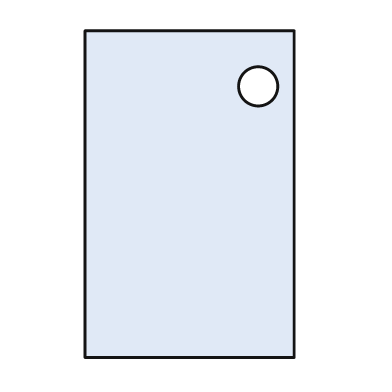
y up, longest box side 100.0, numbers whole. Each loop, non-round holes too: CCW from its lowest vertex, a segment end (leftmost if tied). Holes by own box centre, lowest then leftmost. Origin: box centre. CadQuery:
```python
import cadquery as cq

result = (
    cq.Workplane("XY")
    .moveTo(-32.0, -50.0)
    .lineTo(32.0, -50.0)
    .lineTo(32.0, 50.0)
    .lineTo(-32.0, 50.0)
    .close()
    .moveTo(21.0, 33.0)
    .circle(6.0)
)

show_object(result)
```